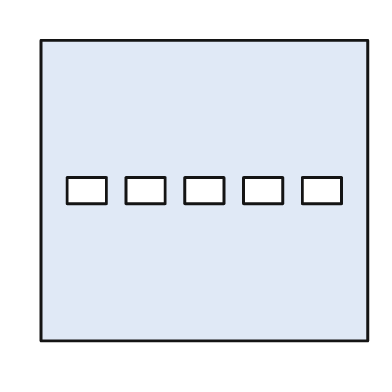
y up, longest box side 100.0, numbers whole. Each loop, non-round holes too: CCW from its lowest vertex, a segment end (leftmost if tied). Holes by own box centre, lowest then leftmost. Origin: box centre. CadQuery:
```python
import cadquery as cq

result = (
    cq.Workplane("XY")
    .moveTo(-50.0, -46.0)
    .lineTo(50.0, -46.0)
    .lineTo(50.0, 46.0)
    .lineTo(-50.0, 46.0)
    .close()
    .moveTo(-42.0, -4.0)
    .lineTo(-30.0, -4.0)
    .lineTo(-30.0, 4.0)
    .lineTo(-42.0, 4.0)
    .close()
    .moveTo(-24.0, -4.0)
    .lineTo(-12.0, -4.0)
    .lineTo(-12.0, 4.0)
    .lineTo(-24.0, 4.0)
    .close()
    .moveTo(-6.0, -4.0)
    .lineTo(6.0, -4.0)
    .lineTo(6.0, 4.0)
    .lineTo(-6.0, 4.0)
    .close()
    .moveTo(12.0, -4.0)
    .lineTo(24.0, -4.0)
    .lineTo(24.0, 4.0)
    .lineTo(12.0, 4.0)
    .close()
    .moveTo(30.0, -4.0)
    .lineTo(42.0, -4.0)
    .lineTo(42.0, 4.0)
    .lineTo(30.0, 4.0)
    .close()
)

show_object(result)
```